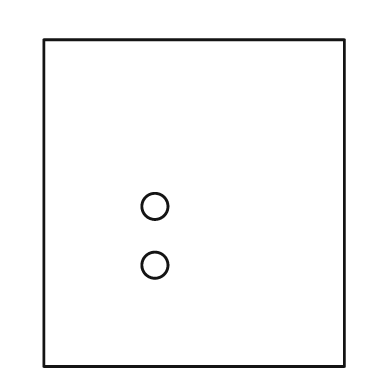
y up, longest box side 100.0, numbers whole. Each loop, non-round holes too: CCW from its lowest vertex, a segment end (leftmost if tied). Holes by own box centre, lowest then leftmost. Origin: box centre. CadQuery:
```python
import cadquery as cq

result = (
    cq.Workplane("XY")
    .moveTo(-46.0, -50.0)
    .lineTo(46.0, -50.0)
    .lineTo(46.0, 50.0)
    .lineTo(-46.0, 50.0)
    .close()
    .moveTo(-12.0, -19.0)
    .circle(4.0)
    .moveTo(-12.0, -1.0)
    .circle(4.0)
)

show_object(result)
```